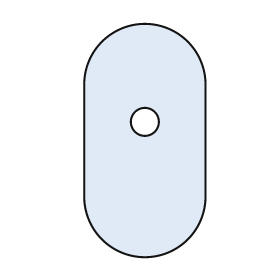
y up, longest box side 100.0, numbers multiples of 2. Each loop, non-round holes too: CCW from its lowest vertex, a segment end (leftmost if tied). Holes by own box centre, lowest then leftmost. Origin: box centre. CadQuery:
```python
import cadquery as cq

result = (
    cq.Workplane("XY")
    .moveTo(-26.0, -24.0)
    .threePointArc((0.0, -50.0), (26.0, -24.0))
    .lineTo(26.0, 24.0)
    .threePointArc((0.0, 50.0), (-26.0, 24.0))
    .close()
    .moveTo(0.0, 8.0)
    .circle(6.0)
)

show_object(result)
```